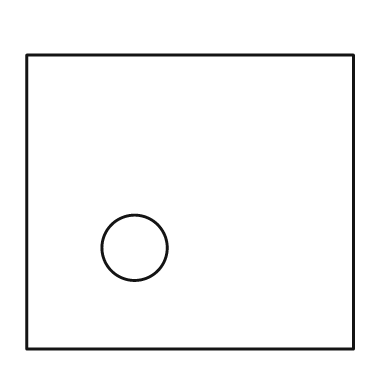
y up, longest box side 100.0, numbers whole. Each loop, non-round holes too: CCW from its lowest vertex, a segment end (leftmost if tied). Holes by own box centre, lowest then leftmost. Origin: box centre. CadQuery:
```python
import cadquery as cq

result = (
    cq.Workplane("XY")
    .moveTo(-50.0, -45.0)
    .lineTo(50.0, -45.0)
    .lineTo(50.0, 45.0)
    .lineTo(-50.0, 45.0)
    .close()
    .moveTo(-17.0, -14.0)
    .circle(10.0)
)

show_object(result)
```